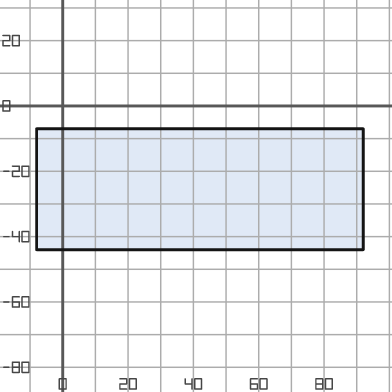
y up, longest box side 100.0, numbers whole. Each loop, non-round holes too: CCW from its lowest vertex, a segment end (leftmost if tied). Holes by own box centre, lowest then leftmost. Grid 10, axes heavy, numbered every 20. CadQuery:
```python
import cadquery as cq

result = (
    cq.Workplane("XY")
    .moveTo(-8.0, -44.0)
    .lineTo(92.0, -44.0)
    .lineTo(92.0, -7.0)
    .lineTo(-8.0, -7.0)
    .close()
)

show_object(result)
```